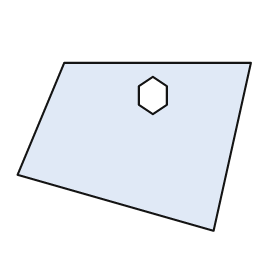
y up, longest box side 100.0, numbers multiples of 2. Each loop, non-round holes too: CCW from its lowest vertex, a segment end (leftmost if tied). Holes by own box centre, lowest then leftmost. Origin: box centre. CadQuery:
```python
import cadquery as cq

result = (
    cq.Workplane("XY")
    .moveTo(34.0, -36.0)
    .lineTo(50.0, 36.0)
    .lineTo(-30.0, 36.0)
    .lineTo(-50.0, -12.0)
    .close()
    .moveTo(8.0, 14.0)
    .lineTo(14.0, 18.0)
    .lineTo(14.0, 26.0)
    .lineTo(8.0, 30.0)
    .lineTo(2.0, 26.0)
    .lineTo(2.0, 18.0)
    .close()
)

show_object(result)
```